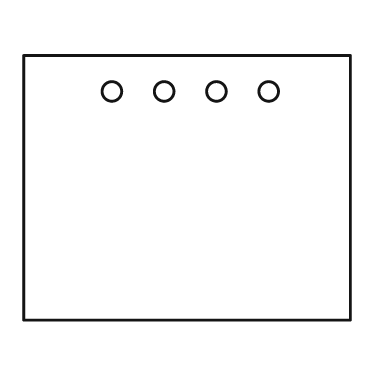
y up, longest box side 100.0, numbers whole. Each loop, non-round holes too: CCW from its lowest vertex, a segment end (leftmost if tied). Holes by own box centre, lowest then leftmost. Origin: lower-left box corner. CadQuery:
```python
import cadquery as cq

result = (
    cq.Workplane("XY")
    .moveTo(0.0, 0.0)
    .lineTo(100.0, 0.0)
    .lineTo(100.0, 81.0)
    .lineTo(0.0, 81.0)
    .close()
    .moveTo(27.0, 70.0)
    .circle(3.0)
    .moveTo(43.0, 70.0)
    .circle(3.0)
    .moveTo(59.0, 70.0)
    .circle(3.0)
    .moveTo(75.0, 70.0)
    .circle(3.0)
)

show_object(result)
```